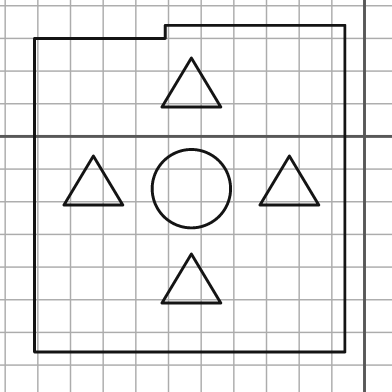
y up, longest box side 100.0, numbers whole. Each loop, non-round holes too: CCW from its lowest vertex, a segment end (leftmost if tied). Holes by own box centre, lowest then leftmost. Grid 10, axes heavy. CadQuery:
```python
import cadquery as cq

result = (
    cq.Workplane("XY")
    .moveTo(-101.0, -66.0)
    .lineTo(-6.0, -66.0)
    .lineTo(-6.0, 34.0)
    .lineTo(-61.0, 34.0)
    .lineTo(-61.0, 30.0)
    .lineTo(-101.0, 30.0)
    .close()
    .moveTo(-62.0, -51.0)
    .lineTo(-44.0, -51.0)
    .lineTo(-53.0, -36.0)
    .close()
    .moveTo(-53.0, -16.0)
    .circle(12.0)
    .moveTo(-92.0, -21.0)
    .lineTo(-74.0, -21.0)
    .lineTo(-83.0, -6.0)
    .close()
    .moveTo(-32.0, -21.0)
    .lineTo(-14.0, -21.0)
    .lineTo(-23.0, -6.0)
    .close()
    .moveTo(-62.0, 9.0)
    .lineTo(-44.0, 9.0)
    .lineTo(-53.0, 24.0)
    .close()
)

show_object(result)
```